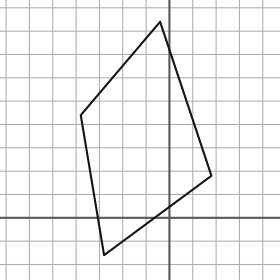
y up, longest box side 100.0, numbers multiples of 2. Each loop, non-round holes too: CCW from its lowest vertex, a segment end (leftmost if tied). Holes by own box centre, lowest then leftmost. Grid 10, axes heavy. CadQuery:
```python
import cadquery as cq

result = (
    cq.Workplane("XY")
    .moveTo(-28.0, -16.0)
    .lineTo(18.0, 18.0)
    .lineTo(-4.0, 84.0)
    .lineTo(-38.0, 44.0)
    .close()
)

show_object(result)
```